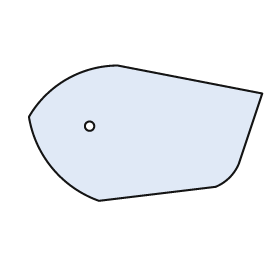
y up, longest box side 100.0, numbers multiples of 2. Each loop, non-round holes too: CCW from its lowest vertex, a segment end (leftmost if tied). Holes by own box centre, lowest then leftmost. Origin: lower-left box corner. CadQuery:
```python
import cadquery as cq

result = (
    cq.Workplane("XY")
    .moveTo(30.0, 0.0)
    .lineTo(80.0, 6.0)
    .threePointArc((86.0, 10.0), (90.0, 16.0))
    .lineTo(100.0, 46.0)
    .lineTo(38.0, 58.0)
    .threePointArc((16.0, 52.0), (0.0, 36.0))
    .threePointArc((10.0, 14.0), (30.0, 0.0))
    .close()
    .moveTo(26.0, 32.0)
    .circle(2.0)
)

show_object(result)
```